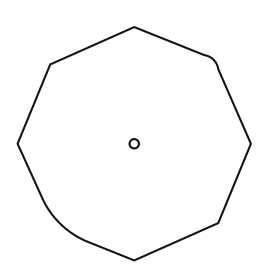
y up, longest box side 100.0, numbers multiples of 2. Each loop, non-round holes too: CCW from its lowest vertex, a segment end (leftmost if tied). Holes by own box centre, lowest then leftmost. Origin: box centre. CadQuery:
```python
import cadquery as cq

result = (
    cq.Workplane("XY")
    .moveTo(0.0, -50.0)
    .lineTo(36.0, -34.0)
    .lineTo(50.0, 0.0)
    .lineTo(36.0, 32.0)
    .threePointArc((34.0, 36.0), (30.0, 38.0))
    .lineTo(0.0, 50.0)
    .lineTo(-36.0, 34.0)
    .lineTo(-50.0, 0.0)
    .lineTo(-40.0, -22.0)
    .threePointArc((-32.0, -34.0), (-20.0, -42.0))
    .close()
    .moveTo(0.0, 0.0)
    .circle(2.0)
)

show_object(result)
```